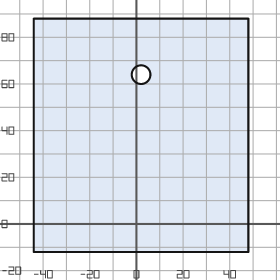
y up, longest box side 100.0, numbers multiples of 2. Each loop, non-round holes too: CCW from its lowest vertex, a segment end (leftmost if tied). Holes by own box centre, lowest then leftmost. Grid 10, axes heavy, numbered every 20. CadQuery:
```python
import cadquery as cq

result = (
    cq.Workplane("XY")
    .moveTo(-44.0, -12.0)
    .lineTo(48.0, -12.0)
    .lineTo(48.0, 88.0)
    .lineTo(-44.0, 88.0)
    .close()
    .moveTo(2.0, 64.0)
    .circle(4.0)
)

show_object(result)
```